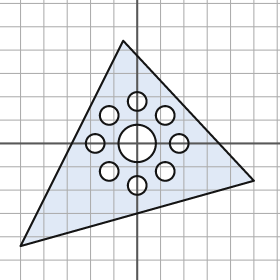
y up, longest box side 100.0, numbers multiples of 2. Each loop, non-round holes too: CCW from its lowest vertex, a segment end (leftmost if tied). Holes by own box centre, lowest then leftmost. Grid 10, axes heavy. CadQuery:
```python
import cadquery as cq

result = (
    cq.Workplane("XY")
    .moveTo(-50.0, -44.0)
    .lineTo(50.0, -16.0)
    .lineTo(-6.0, 44.0)
    .close()
    .moveTo(0.0, -18.0)
    .circle(4.0)
    .moveTo(-12.0, -12.0)
    .circle(4.0)
    .moveTo(12.0, -12.0)
    .circle(4.0)
    .moveTo(-18.0, 0.0)
    .circle(4.0)
    .moveTo(0.0, 0.0)
    .circle(8.0)
    .moveTo(18.0, 0.0)
    .circle(4.0)
    .moveTo(-12.0, 12.0)
    .circle(4.0)
    .moveTo(12.0, 12.0)
    .circle(4.0)
    .moveTo(0.0, 18.0)
    .circle(4.0)
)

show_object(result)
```